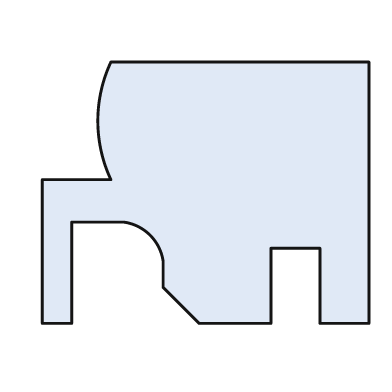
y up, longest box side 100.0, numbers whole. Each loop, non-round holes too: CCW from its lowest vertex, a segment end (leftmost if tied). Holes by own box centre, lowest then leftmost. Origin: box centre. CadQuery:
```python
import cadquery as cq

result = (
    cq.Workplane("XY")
    .moveTo(-50.0, -40.0)
    .lineTo(-41.0, -40.0)
    .lineTo(-41.0, -9.0)
    .lineTo(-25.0, -9.0)
    .threePointArc((-17.0, -13.0), (-13.0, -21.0))
    .lineTo(-13.0, -29.0)
    .lineTo(-2.0, -40.0)
    .lineTo(20.0, -40.0)
    .lineTo(20.0, -17.0)
    .lineTo(35.0, -17.0)
    .lineTo(35.0, -40.0)
    .lineTo(50.0, -40.0)
    .lineTo(50.0, 40.0)
    .lineTo(-29.0, 40.0)
    .threePointArc((-33.0, 22.0), (-29.0, 4.0))
    .lineTo(-50.0, 4.0)
    .close()
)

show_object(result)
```